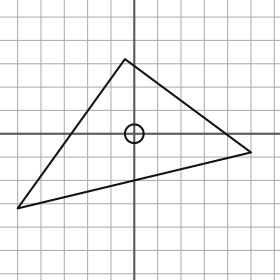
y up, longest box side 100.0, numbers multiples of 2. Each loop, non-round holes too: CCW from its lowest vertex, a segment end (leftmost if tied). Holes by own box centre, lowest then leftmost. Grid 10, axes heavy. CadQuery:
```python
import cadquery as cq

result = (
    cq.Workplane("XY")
    .moveTo(-50.0, -32.0)
    .lineTo(50.0, -8.0)
    .lineTo(-4.0, 32.0)
    .close()
    .moveTo(0.0, 0.0)
    .circle(4.0)
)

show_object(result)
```